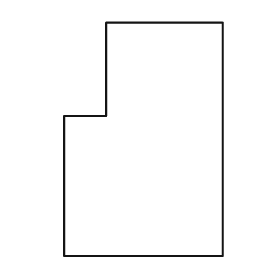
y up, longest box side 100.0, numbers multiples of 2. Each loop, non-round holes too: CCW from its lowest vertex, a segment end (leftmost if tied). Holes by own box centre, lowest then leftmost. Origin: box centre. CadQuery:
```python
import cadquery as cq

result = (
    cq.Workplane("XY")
    .moveTo(-34.0, -50.0)
    .lineTo(34.0, -50.0)
    .lineTo(34.0, 50.0)
    .lineTo(-16.0, 50.0)
    .lineTo(-16.0, 10.0)
    .lineTo(-34.0, 10.0)
    .close()
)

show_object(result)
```